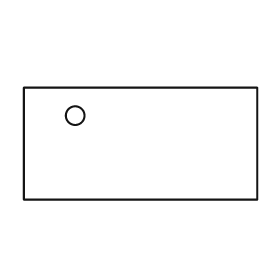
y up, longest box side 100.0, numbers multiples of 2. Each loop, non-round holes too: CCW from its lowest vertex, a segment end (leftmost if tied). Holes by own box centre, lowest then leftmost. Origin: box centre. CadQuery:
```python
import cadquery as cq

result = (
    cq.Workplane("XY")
    .moveTo(-50.0, -24.0)
    .lineTo(50.0, -24.0)
    .lineTo(50.0, 24.0)
    .lineTo(-50.0, 24.0)
    .close()
    .moveTo(-28.0, 12.0)
    .circle(4.0)
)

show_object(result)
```